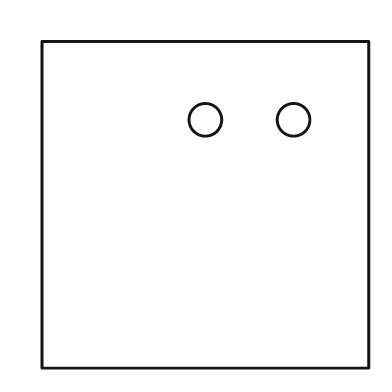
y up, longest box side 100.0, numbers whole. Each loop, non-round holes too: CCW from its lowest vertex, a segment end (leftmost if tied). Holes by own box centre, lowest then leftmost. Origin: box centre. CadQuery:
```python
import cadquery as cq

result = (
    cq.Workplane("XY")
    .moveTo(-50.0, -50.0)
    .lineTo(50.0, -50.0)
    .lineTo(50.0, 50.0)
    .lineTo(-50.0, 50.0)
    .close()
    .moveTo(0.0, 26.0)
    .circle(5.0)
    .moveTo(27.0, 26.0)
    .circle(5.0)
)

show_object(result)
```